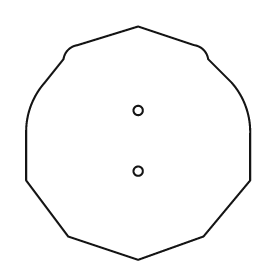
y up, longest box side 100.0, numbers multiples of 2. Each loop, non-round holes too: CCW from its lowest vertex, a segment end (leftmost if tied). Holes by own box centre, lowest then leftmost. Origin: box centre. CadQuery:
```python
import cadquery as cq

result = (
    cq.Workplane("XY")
    .moveTo(0.0, -50.0)
    .lineTo(28.0, -40.0)
    .lineTo(48.0, -16.0)
    .lineTo(48.0, 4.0)
    .threePointArc((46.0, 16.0), (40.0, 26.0))
    .lineTo(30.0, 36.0)
    .threePointArc((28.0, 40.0), (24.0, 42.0))
    .lineTo(0.0, 50.0)
    .lineTo(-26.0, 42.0)
    .threePointArc((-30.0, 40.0), (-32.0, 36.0))
    .lineTo(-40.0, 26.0)
    .threePointArc((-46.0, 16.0), (-48.0, 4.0))
    .lineTo(-48.0, -16.0)
    .lineTo(-30.0, -40.0)
    .close()
    .moveTo(0.0, -12.0)
    .circle(2.0)
    .moveTo(0.0, 14.0)
    .circle(2.0)
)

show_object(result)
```